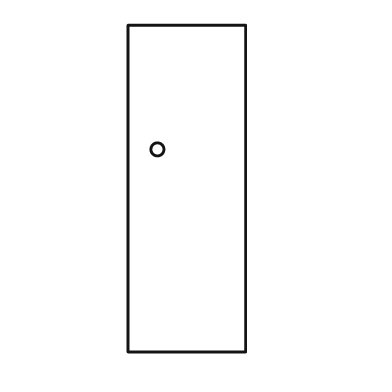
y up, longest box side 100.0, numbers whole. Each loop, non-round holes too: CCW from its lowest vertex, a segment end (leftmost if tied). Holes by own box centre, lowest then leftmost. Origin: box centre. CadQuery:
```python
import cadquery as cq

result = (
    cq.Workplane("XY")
    .moveTo(-18.0, -50.0)
    .lineTo(18.0, -50.0)
    .lineTo(18.0, 50.0)
    .lineTo(-18.0, 50.0)
    .close()
    .moveTo(-9.0, 12.0)
    .circle(2.0)
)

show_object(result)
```